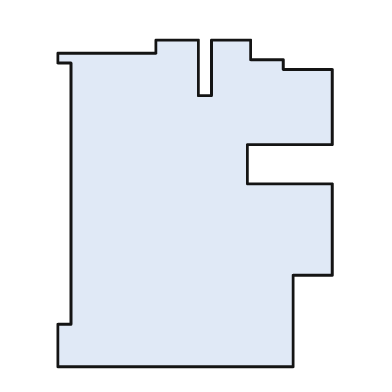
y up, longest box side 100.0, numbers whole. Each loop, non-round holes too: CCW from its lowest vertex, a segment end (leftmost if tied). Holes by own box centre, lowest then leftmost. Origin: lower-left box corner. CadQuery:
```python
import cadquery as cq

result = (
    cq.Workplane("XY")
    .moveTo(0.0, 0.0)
    .lineTo(72.0, 0.0)
    .lineTo(72.0, 28.0)
    .lineTo(84.0, 28.0)
    .lineTo(84.0, 56.0)
    .lineTo(58.0, 56.0)
    .lineTo(58.0, 68.0)
    .lineTo(84.0, 68.0)
    .lineTo(84.0, 91.0)
    .lineTo(69.0, 91.0)
    .lineTo(69.0, 94.0)
    .lineTo(59.0, 94.0)
    .lineTo(59.0, 100.0)
    .lineTo(47.0, 100.0)
    .lineTo(47.0, 83.0)
    .lineTo(43.0, 83.0)
    .lineTo(43.0, 100.0)
    .lineTo(30.0, 100.0)
    .lineTo(30.0, 96.0)
    .lineTo(0.0, 96.0)
    .lineTo(0.0, 93.0)
    .lineTo(4.0, 93.0)
    .lineTo(4.0, 13.0)
    .lineTo(0.0, 13.0)
    .close()
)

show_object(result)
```